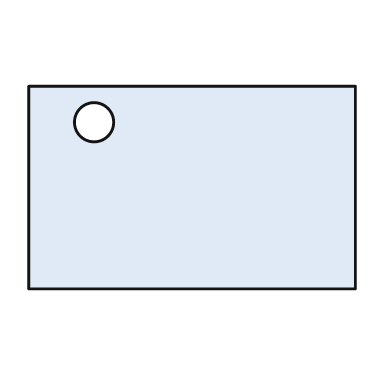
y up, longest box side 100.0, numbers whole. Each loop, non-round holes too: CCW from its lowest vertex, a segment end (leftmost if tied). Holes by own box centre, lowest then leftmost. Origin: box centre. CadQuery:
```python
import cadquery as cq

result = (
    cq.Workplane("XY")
    .moveTo(-50.0, -31.0)
    .lineTo(50.0, -31.0)
    .lineTo(50.0, 31.0)
    .lineTo(-50.0, 31.0)
    .close()
    .moveTo(-30.0, 20.0)
    .circle(6.0)
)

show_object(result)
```